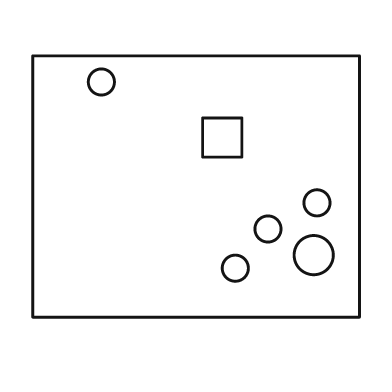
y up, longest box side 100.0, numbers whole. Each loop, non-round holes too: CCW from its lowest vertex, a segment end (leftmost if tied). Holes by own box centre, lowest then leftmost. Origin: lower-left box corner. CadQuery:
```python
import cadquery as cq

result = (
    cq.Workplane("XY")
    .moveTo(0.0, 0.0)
    .lineTo(100.0, 0.0)
    .lineTo(100.0, 80.0)
    .lineTo(0.0, 80.0)
    .close()
    .moveTo(62.0, 15.0)
    .circle(4.0)
    .moveTo(86.0, 19.0)
    .circle(6.0)
    .moveTo(72.0, 27.0)
    .circle(4.0)
    .moveTo(87.0, 35.0)
    .circle(4.0)
    .moveTo(52.0, 49.0)
    .lineTo(64.0, 49.0)
    .lineTo(64.0, 61.0)
    .lineTo(52.0, 61.0)
    .close()
    .moveTo(21.0, 72.0)
    .circle(4.0)
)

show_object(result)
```